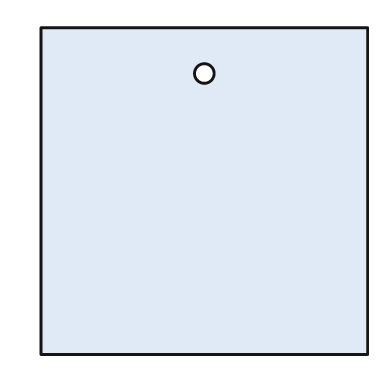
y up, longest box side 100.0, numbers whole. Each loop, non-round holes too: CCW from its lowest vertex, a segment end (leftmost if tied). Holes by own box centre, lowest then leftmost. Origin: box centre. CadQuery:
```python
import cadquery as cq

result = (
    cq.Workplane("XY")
    .moveTo(-50.0, -50.0)
    .lineTo(50.0, -50.0)
    .lineTo(50.0, 50.0)
    .lineTo(-50.0, 50.0)
    .close()
    .moveTo(0.0, 36.0)
    .circle(3.0)
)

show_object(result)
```